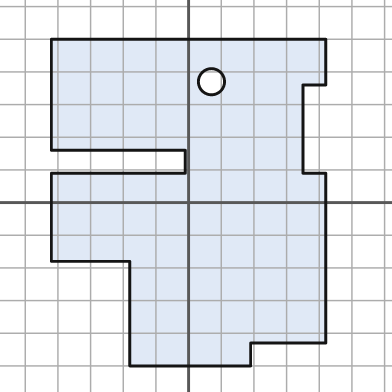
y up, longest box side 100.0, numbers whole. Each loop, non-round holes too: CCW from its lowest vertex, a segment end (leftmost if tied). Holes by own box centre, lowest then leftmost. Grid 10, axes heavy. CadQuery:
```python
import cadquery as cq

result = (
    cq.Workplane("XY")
    .moveTo(-18.0, -50.0)
    .lineTo(19.0, -50.0)
    .lineTo(19.0, -43.0)
    .lineTo(42.0, -43.0)
    .lineTo(42.0, 9.0)
    .lineTo(35.0, 9.0)
    .lineTo(35.0, 36.0)
    .lineTo(42.0, 36.0)
    .lineTo(42.0, 50.0)
    .lineTo(-42.0, 50.0)
    .lineTo(-42.0, 16.0)
    .lineTo(-1.0, 16.0)
    .lineTo(-1.0, 9.0)
    .lineTo(-42.0, 9.0)
    .lineTo(-42.0, -18.0)
    .lineTo(-18.0, -18.0)
    .close()
    .moveTo(7.0, 37.0)
    .circle(4.0)
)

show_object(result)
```